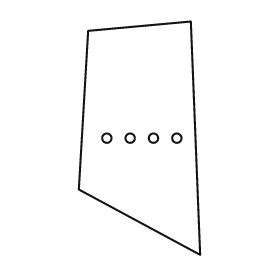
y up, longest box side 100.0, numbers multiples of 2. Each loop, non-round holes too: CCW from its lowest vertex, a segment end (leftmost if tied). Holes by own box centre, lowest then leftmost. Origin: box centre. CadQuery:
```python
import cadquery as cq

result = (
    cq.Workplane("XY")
    .moveTo(26.0, -50.0)
    .lineTo(22.0, 50.0)
    .lineTo(-22.0, 46.0)
    .lineTo(-26.0, -22.0)
    .close()
    .moveTo(-14.0, 0.0)
    .circle(2.0)
    .moveTo(-4.0, 0.0)
    .circle(2.0)
    .moveTo(6.0, 0.0)
    .circle(2.0)
    .moveTo(16.0, 0.0)
    .circle(2.0)
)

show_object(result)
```